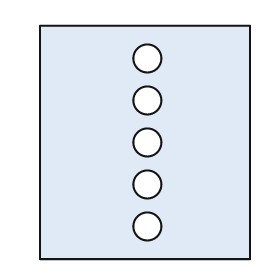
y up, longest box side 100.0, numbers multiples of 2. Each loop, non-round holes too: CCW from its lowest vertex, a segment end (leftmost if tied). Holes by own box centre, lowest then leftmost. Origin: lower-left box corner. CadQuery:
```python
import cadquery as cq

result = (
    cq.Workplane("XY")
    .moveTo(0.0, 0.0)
    .lineTo(90.0, 0.0)
    .lineTo(90.0, 100.0)
    .lineTo(0.0, 100.0)
    .close()
    .moveTo(46.0, 14.0)
    .circle(6.0)
    .moveTo(46.0, 32.0)
    .circle(6.0)
    .moveTo(46.0, 50.0)
    .circle(6.0)
    .moveTo(46.0, 68.0)
    .circle(6.0)
    .moveTo(46.0, 86.0)
    .circle(6.0)
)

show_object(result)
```